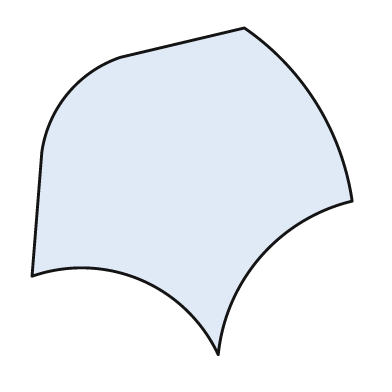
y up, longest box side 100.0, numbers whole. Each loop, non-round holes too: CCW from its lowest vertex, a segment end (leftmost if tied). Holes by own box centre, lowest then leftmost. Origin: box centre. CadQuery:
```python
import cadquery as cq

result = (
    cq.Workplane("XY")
    .moveTo(8.0, -50.0)
    .threePointArc((21.0, -20.0), (49.0, -3.0))
    .threePointArc((38.0, 27.0), (16.0, 50.0))
    .lineTo(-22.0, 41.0)
    .threePointArc((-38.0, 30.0), (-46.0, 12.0))
    .lineTo(-49.0, -26.0)
    .threePointArc((-16.0, -27.0), (8.0, -50.0))
    .close()
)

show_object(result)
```